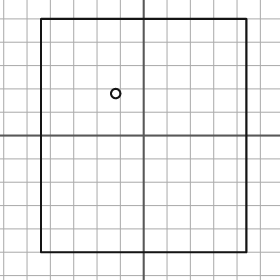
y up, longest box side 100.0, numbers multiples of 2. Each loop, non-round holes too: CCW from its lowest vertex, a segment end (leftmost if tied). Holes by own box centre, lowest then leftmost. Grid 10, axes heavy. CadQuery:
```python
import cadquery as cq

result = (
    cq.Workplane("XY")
    .moveTo(-44.0, -50.0)
    .lineTo(44.0, -50.0)
    .lineTo(44.0, 50.0)
    .lineTo(-44.0, 50.0)
    .close()
    .moveTo(-12.0, 18.0)
    .circle(2.0)
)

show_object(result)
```